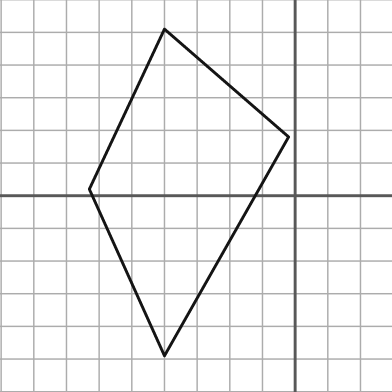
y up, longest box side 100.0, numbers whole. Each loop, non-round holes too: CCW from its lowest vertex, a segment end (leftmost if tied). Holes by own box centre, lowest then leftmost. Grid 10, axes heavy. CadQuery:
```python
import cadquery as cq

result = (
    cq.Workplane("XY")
    .moveTo(-40.0, -49.0)
    .lineTo(-2.0, 18.0)
    .lineTo(-40.0, 51.0)
    .lineTo(-63.0, 2.0)
    .close()
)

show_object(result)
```